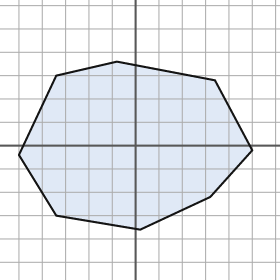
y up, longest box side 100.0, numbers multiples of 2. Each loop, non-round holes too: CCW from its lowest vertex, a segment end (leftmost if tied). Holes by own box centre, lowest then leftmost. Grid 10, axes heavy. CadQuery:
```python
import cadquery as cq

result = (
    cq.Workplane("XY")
    .moveTo(2.0, -36.0)
    .lineTo(32.0, -22.0)
    .lineTo(50.0, -2.0)
    .lineTo(34.0, 28.0)
    .lineTo(-8.0, 36.0)
    .lineTo(-34.0, 30.0)
    .lineTo(-50.0, -4.0)
    .lineTo(-34.0, -30.0)
    .close()
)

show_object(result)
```